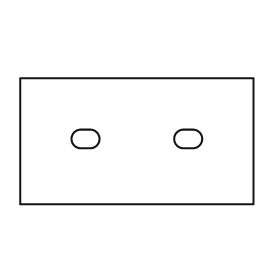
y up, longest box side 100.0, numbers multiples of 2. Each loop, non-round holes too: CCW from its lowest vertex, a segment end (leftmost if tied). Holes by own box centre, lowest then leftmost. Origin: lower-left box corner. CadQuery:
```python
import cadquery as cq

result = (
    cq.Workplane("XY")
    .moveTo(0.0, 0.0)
    .lineTo(100.0, 0.0)
    .lineTo(100.0, 54.0)
    .lineTo(0.0, 54.0)
    .close()
    .moveTo(26.0, 24.0)
    .lineTo(30.0, 24.0)
    .threePointArc((34.0, 28.0), (30.0, 32.0))
    .lineTo(26.0, 32.0)
    .threePointArc((22.0, 28.0), (26.0, 24.0))
    .close()
    .moveTo(70.0, 24.0)
    .lineTo(74.0, 24.0)
    .threePointArc((78.0, 28.0), (74.0, 32.0))
    .lineTo(70.0, 32.0)
    .threePointArc((66.0, 28.0), (70.0, 24.0))
    .close()
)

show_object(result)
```